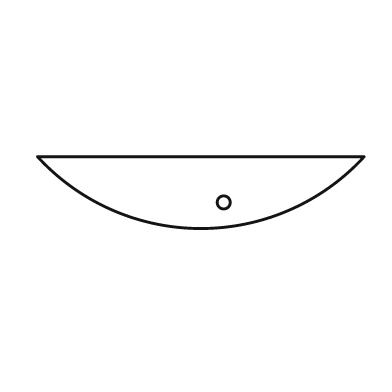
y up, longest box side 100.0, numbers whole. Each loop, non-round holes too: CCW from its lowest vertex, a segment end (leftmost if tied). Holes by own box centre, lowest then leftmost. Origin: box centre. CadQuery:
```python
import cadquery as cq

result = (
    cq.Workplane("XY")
    .moveTo(-50.0, 11.0)
    .threePointArc((0.0, -11.0), (50.0, 11.0))
    .close()
    .moveTo(7.0, -3.0)
    .circle(2.0)
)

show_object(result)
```